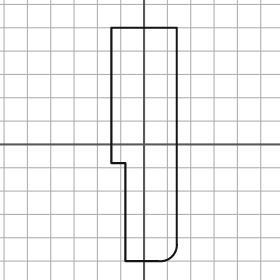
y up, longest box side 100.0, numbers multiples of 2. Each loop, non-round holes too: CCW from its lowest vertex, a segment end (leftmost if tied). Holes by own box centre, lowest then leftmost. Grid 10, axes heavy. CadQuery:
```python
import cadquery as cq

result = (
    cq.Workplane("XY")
    .moveTo(-8.0, -50.0)
    .lineTo(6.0, -50.0)
    .threePointArc((12.0, -48.0), (14.0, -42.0))
    .lineTo(14.0, 50.0)
    .lineTo(-14.0, 50.0)
    .lineTo(-14.0, -8.0)
    .lineTo(-8.0, -8.0)
    .close()
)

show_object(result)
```